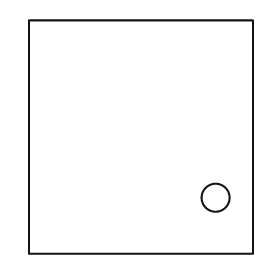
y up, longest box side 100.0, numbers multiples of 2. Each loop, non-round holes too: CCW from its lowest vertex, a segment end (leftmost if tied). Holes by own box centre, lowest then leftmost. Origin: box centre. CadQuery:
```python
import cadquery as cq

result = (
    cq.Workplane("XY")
    .moveTo(-48.0, -50.0)
    .lineTo(48.0, -50.0)
    .lineTo(48.0, 50.0)
    .lineTo(-48.0, 50.0)
    .close()
    .moveTo(32.0, -26.0)
    .circle(6.0)
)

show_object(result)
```